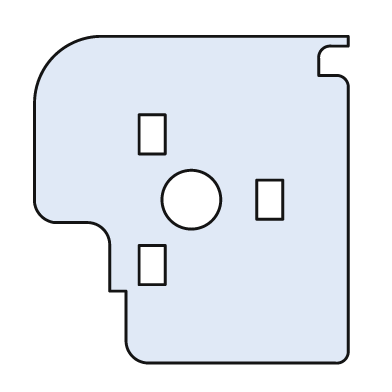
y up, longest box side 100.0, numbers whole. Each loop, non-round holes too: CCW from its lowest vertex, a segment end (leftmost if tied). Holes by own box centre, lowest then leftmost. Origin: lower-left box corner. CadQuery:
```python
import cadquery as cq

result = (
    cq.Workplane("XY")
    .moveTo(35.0, 0.0)
    .lineTo(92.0, 0.0)
    .threePointArc((95.0, 1.0), (96.0, 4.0))
    .lineTo(96.0, 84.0)
    .threePointArc((95.0, 87.0), (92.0, 88.0))
    .lineTo(87.0, 88.0)
    .lineTo(87.0, 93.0)
    .threePointArc((88.0, 96.0), (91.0, 97.0))
    .lineTo(96.0, 97.0)
    .lineTo(96.0, 100.0)
    .lineTo(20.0, 100.0)
    .threePointArc((6.0, 94.0), (0.0, 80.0))
    .lineTo(0.0, 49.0)
    .threePointArc((2.0, 45.0), (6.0, 43.0))
    .lineTo(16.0, 43.0)
    .threePointArc((21.0, 41.0), (23.0, 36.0))
    .lineTo(23.0, 22.0)
    .lineTo(28.0, 22.0)
    .lineTo(28.0, 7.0)
    .threePointArc((30.0, 2.0), (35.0, 0.0))
    .close()
    .moveTo(32.0, 24.0)
    .lineTo(40.0, 24.0)
    .lineTo(40.0, 36.0)
    .lineTo(32.0, 36.0)
    .close()
    .moveTo(48.0, 50.0)
    .circle(9.0)
    .moveTo(68.0, 44.0)
    .lineTo(76.0, 44.0)
    .lineTo(76.0, 56.0)
    .lineTo(68.0, 56.0)
    .close()
    .moveTo(32.0, 64.0)
    .lineTo(40.0, 64.0)
    .lineTo(40.0, 76.0)
    .lineTo(32.0, 76.0)
    .close()
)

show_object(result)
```